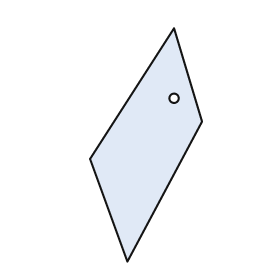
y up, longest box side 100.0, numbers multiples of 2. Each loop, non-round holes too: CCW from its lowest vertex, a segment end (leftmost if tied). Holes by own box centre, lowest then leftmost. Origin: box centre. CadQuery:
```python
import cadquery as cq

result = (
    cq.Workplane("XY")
    .moveTo(-8.0, -50.0)
    .lineTo(24.0, 10.0)
    .lineTo(12.0, 50.0)
    .lineTo(-24.0, -6.0)
    .close()
    .moveTo(12.0, 20.0)
    .circle(2.0)
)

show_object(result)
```